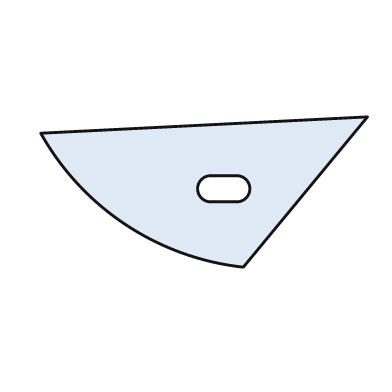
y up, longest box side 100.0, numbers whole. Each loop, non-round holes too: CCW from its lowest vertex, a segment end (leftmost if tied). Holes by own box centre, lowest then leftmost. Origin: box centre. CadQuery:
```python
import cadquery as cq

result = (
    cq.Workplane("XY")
    .moveTo(12.0, -23.0)
    .lineTo(50.0, 23.0)
    .lineTo(-50.0, 18.0)
    .threePointArc((-24.0, -10.0), (12.0, -23.0))
    .close()
    .moveTo(2.0, -3.0)
    .lineTo(10.0, -3.0)
    .threePointArc((14.0, 1.0), (10.0, 5.0))
    .lineTo(2.0, 5.0)
    .threePointArc((-2.0, 1.0), (2.0, -3.0))
    .close()
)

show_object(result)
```